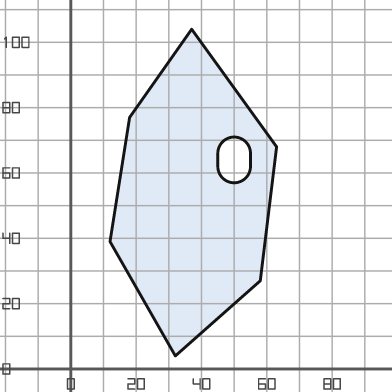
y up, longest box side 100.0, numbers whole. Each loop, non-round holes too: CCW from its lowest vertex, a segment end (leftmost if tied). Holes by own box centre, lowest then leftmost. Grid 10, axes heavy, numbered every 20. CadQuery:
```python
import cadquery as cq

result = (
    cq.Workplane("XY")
    .moveTo(32.0, 4.0)
    .lineTo(58.0, 27.0)
    .lineTo(63.0, 68.0)
    .lineTo(37.0, 104.0)
    .lineTo(18.0, 77.0)
    .lineTo(12.0, 39.0)
    .close()
    .moveTo(45.0, 62.0)
    .threePointArc((50.0, 57.0), (55.0, 62.0))
    .lineTo(55.0, 66.0)
    .threePointArc((50.0, 71.0), (45.0, 66.0))
    .close()
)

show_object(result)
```